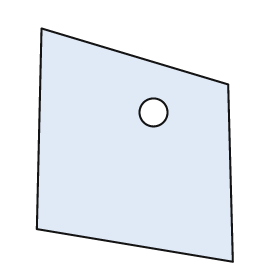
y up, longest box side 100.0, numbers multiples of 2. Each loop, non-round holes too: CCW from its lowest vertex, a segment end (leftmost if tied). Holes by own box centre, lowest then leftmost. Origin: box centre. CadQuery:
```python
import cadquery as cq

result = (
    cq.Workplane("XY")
    .moveTo(42.0, -50.0)
    .lineTo(40.0, 26.0)
    .lineTo(-40.0, 50.0)
    .lineTo(-42.0, -36.0)
    .close()
    .moveTo(8.0, 14.0)
    .circle(6.0)
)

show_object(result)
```